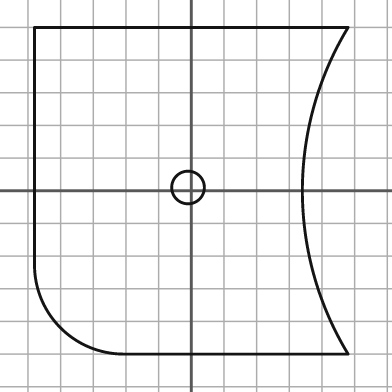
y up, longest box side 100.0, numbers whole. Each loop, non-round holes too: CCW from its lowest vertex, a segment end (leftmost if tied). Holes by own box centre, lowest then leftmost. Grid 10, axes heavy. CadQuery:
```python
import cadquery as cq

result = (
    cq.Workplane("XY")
    .moveTo(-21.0, -50.0)
    .lineTo(48.0, -50.0)
    .threePointArc((34.0, 0.0), (48.0, 50.0))
    .lineTo(-48.0, 50.0)
    .lineTo(-48.0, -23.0)
    .threePointArc((-40.0, -42.0), (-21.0, -50.0))
    .close()
    .moveTo(-1.0, 1.0)
    .circle(5.0)
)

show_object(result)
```